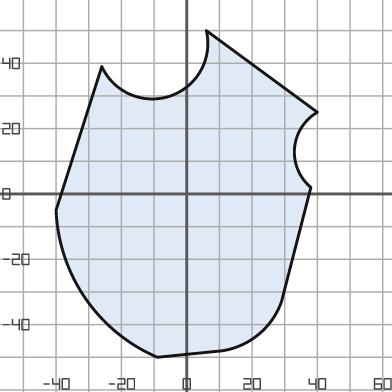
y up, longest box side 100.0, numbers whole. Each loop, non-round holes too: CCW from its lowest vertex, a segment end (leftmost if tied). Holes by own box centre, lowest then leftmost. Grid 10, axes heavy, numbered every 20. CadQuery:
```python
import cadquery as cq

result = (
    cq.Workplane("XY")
    .moveTo(-9.0, -50.0)
    .lineTo(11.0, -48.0)
    .threePointArc((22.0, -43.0), (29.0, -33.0))
    .lineTo(38.0, 2.0)
    .threePointArc((33.0, 14.0), (40.0, 25.0))
    .lineTo(6.0, 50.0)
    .threePointArc((-5.0, 30.0), (-26.0, 39.0))
    .lineTo(-40.0, -5.0)
    .threePointArc((-31.0, -32.0), (-9.0, -50.0))
    .close()
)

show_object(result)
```